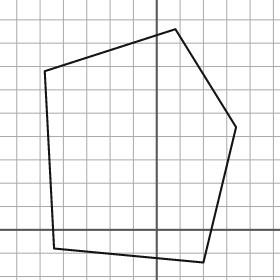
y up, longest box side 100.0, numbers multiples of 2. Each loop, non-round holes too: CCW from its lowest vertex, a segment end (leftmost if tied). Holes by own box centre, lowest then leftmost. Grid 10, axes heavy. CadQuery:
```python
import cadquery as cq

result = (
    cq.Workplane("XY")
    .moveTo(20.0, -14.0)
    .lineTo(34.0, 44.0)
    .lineTo(8.0, 86.0)
    .lineTo(-48.0, 68.0)
    .lineTo(-44.0, -8.0)
    .close()
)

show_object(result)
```